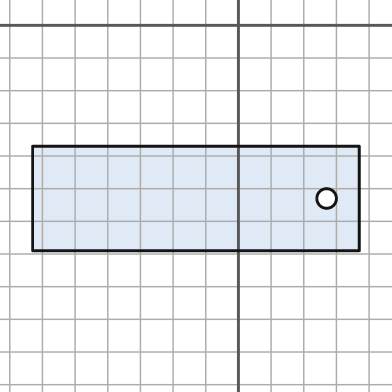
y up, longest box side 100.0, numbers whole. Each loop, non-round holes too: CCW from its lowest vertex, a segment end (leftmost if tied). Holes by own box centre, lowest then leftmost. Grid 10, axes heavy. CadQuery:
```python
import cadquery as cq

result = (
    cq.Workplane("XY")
    .moveTo(-63.0, -69.0)
    .lineTo(37.0, -69.0)
    .lineTo(37.0, -37.0)
    .lineTo(-63.0, -37.0)
    .close()
    .moveTo(27.0, -53.0)
    .circle(3.0)
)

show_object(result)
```